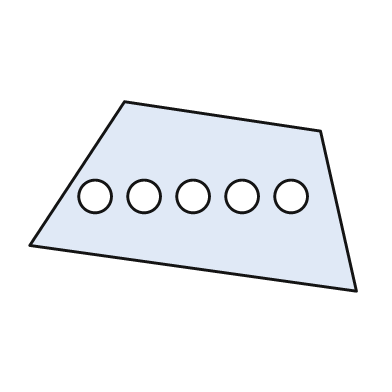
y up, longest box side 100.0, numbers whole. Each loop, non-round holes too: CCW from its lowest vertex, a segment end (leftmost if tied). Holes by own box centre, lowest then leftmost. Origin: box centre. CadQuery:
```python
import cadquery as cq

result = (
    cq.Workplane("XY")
    .moveTo(50.0, -29.0)
    .lineTo(39.0, 20.0)
    .lineTo(-21.0, 29.0)
    .lineTo(-50.0, -15.0)
    .close()
    .moveTo(-30.0, 0.0)
    .circle(5.0)
    .moveTo(-15.0, 0.0)
    .circle(5.0)
    .moveTo(0.0, 0.0)
    .circle(5.0)
    .moveTo(15.0, 0.0)
    .circle(5.0)
    .moveTo(30.0, 0.0)
    .circle(5.0)
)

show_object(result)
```